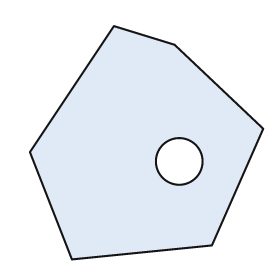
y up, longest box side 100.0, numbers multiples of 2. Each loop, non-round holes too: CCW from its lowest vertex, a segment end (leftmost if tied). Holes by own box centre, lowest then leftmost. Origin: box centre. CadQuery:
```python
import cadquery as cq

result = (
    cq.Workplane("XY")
    .moveTo(-32.0, -50.0)
    .lineTo(28.0, -44.0)
    .lineTo(50.0, 6.0)
    .lineTo(12.0, 42.0)
    .lineTo(-14.0, 50.0)
    .lineTo(-50.0, -4.0)
    .close()
    .moveTo(14.0, -8.0)
    .circle(10.0)
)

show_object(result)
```